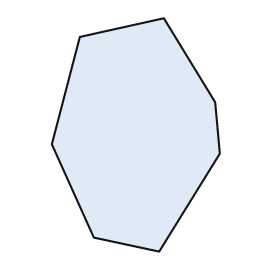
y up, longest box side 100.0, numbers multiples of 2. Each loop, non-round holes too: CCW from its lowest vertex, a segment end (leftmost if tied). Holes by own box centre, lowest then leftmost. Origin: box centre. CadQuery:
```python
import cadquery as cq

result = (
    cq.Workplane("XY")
    .moveTo(10.0, -50.0)
    .lineTo(36.0, -8.0)
    .lineTo(34.0, 14.0)
    .lineTo(12.0, 50.0)
    .lineTo(-24.0, 42.0)
    .lineTo(-36.0, -4.0)
    .lineTo(-18.0, -44.0)
    .close()
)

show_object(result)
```